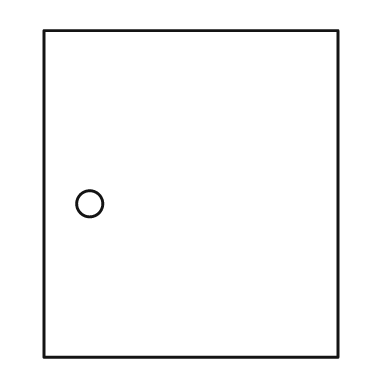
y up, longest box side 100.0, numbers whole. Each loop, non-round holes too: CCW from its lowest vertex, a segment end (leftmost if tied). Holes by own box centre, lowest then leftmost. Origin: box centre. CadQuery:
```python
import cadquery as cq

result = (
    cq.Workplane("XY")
    .moveTo(-45.0, -50.0)
    .lineTo(45.0, -50.0)
    .lineTo(45.0, 50.0)
    .lineTo(-45.0, 50.0)
    .close()
    .moveTo(-31.0, -3.0)
    .circle(4.0)
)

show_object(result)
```